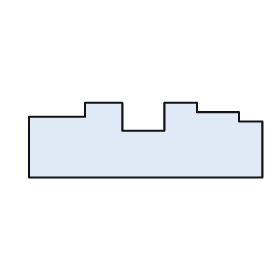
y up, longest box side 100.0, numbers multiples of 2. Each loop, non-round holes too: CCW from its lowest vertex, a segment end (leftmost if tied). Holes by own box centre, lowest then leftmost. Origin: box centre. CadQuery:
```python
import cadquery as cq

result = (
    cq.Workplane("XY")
    .moveTo(-50.0, -16.0)
    .lineTo(50.0, -16.0)
    .lineTo(50.0, 8.0)
    .lineTo(40.0, 8.0)
    .lineTo(40.0, 12.0)
    .lineTo(22.0, 12.0)
    .lineTo(22.0, 16.0)
    .lineTo(8.0, 16.0)
    .lineTo(8.0, 4.0)
    .lineTo(-10.0, 4.0)
    .lineTo(-10.0, 16.0)
    .lineTo(-26.0, 16.0)
    .lineTo(-26.0, 10.0)
    .lineTo(-50.0, 10.0)
    .close()
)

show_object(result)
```